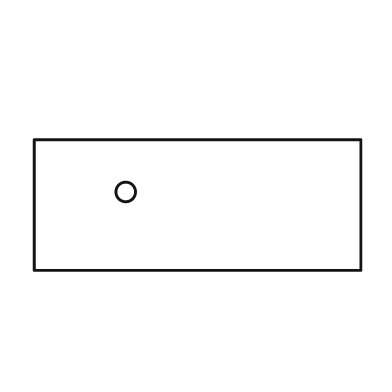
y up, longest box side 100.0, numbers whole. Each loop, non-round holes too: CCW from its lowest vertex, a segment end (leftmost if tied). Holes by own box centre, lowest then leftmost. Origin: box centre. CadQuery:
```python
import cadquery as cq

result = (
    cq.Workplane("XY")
    .moveTo(-50.0, -20.0)
    .lineTo(50.0, -20.0)
    .lineTo(50.0, 20.0)
    .lineTo(-50.0, 20.0)
    .close()
    .moveTo(-22.0, 4.0)
    .circle(3.0)
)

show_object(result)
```